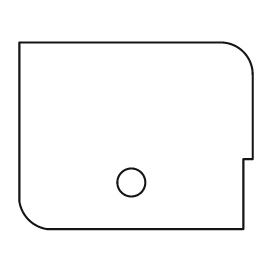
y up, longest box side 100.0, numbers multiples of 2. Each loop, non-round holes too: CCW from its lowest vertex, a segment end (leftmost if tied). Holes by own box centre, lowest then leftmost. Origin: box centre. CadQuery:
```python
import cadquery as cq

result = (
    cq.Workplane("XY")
    .moveTo(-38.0, -40.0)
    .lineTo(46.0, -40.0)
    .lineTo(46.0, -10.0)
    .lineTo(50.0, -10.0)
    .lineTo(50.0, 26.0)
    .threePointArc((46.0, 36.0), (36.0, 40.0))
    .lineTo(-50.0, 40.0)
    .lineTo(-50.0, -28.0)
    .threePointArc((-46.0, -36.0), (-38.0, -40.0))
    .close()
    .moveTo(-2.0, -20.0)
    .circle(6.0)
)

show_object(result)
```